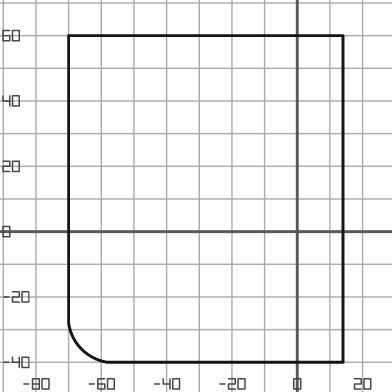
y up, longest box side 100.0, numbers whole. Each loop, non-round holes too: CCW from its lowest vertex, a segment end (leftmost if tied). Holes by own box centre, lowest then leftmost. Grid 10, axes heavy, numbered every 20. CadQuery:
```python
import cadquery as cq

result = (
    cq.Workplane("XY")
    .moveTo(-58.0, -40.0)
    .lineTo(14.0, -40.0)
    .lineTo(14.0, 60.0)
    .lineTo(-70.0, 60.0)
    .lineTo(-70.0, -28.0)
    .threePointArc((-66.0, -36.0), (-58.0, -40.0))
    .close()
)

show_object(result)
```